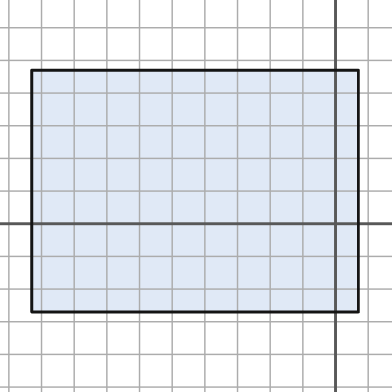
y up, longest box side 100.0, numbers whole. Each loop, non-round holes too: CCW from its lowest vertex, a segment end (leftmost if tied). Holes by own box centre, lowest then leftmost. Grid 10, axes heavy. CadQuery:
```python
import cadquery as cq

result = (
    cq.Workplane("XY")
    .moveTo(-93.0, -27.0)
    .lineTo(7.0, -27.0)
    .lineTo(7.0, 47.0)
    .lineTo(-93.0, 47.0)
    .close()
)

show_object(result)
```